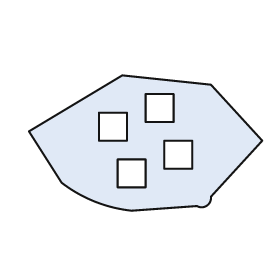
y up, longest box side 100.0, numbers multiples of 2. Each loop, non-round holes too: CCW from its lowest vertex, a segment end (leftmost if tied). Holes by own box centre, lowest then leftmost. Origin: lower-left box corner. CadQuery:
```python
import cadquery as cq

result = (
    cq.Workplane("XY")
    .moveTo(44.0, 0.0)
    .lineTo(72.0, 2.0)
    .threePointArc((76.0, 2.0), (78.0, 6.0))
    .lineTo(100.0, 30.0)
    .lineTo(78.0, 54.0)
    .lineTo(40.0, 58.0)
    .lineTo(0.0, 34.0)
    .lineTo(14.0, 12.0)
    .threePointArc((28.0, 4.0), (44.0, 0.0))
    .close()
    .moveTo(38.0, 10.0)
    .lineTo(50.0, 10.0)
    .lineTo(50.0, 22.0)
    .lineTo(38.0, 22.0)
    .close()
    .moveTo(58.0, 18.0)
    .lineTo(70.0, 18.0)
    .lineTo(70.0, 30.0)
    .lineTo(58.0, 30.0)
    .close()
    .moveTo(30.0, 30.0)
    .lineTo(42.0, 30.0)
    .lineTo(42.0, 42.0)
    .lineTo(30.0, 42.0)
    .close()
    .moveTo(50.0, 38.0)
    .lineTo(62.0, 38.0)
    .lineTo(62.0, 50.0)
    .lineTo(50.0, 50.0)
    .close()
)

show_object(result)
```